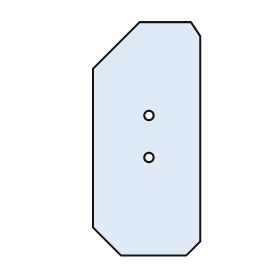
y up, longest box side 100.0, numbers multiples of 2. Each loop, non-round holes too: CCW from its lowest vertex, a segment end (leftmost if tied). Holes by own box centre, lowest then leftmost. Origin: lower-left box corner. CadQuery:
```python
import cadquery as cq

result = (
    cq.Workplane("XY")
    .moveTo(12.0, 0.0)
    .lineTo(40.0, 0.0)
    .lineTo(46.0, 6.0)
    .lineTo(46.0, 94.0)
    .lineTo(42.0, 100.0)
    .lineTo(20.0, 100.0)
    .lineTo(0.0, 80.0)
    .lineTo(0.0, 12.0)
    .close()
    .moveTo(24.0, 42.0)
    .circle(2.0)
    .moveTo(24.0, 60.0)
    .circle(2.0)
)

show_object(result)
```